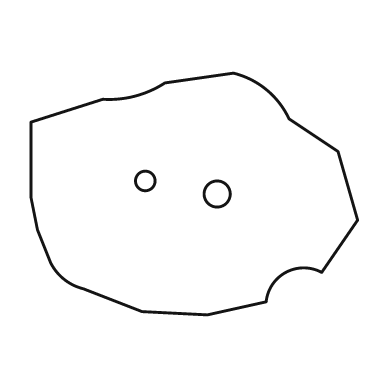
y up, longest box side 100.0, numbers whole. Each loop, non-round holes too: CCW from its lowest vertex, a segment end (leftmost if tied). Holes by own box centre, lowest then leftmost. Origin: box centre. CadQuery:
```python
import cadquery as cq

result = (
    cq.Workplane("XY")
    .moveTo(4.0, -37.0)
    .lineTo(22.0, -33.0)
    .threePointArc((28.0, -24.0), (39.0, -24.0))
    .lineTo(50.0, -8.0)
    .lineTo(44.0, 13.0)
    .lineTo(29.0, 23.0)
    .threePointArc((22.0, 32.0), (12.0, 37.0))
    .lineTo(-9.0, 34.0)
    .threePointArc((-18.0, 30.0), (-28.0, 29.0))
    .lineTo(-50.0, 22.0)
    .lineTo(-50.0, -1.0)
    .lineTo(-48.0, -11.0)
    .lineTo(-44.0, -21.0)
    .threePointArc((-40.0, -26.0), (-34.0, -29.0))
    .lineTo(-16.0, -36.0)
    .close()
    .moveTo(7.0, 0.0)
    .circle(4.0)
    .moveTo(-15.0, 4.0)
    .circle(3.0)
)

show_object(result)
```